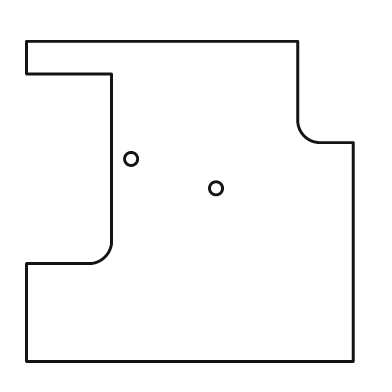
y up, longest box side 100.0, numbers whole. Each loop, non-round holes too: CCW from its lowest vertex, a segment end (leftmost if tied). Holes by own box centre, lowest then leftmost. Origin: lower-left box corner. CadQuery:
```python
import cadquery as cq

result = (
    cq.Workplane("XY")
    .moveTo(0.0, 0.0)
    .lineTo(100.0, 0.0)
    .lineTo(100.0, 67.0)
    .lineTo(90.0, 67.0)
    .threePointArc((85.0, 69.0), (83.0, 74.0))
    .lineTo(83.0, 98.0)
    .lineTo(0.0, 98.0)
    .lineTo(0.0, 88.0)
    .lineTo(26.0, 88.0)
    .lineTo(26.0, 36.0)
    .threePointArc((24.0, 32.0), (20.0, 30.0))
    .lineTo(0.0, 30.0)
    .close()
    .moveTo(58.0, 53.0)
    .circle(2.0)
    .moveTo(32.0, 62.0)
    .circle(2.0)
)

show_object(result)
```